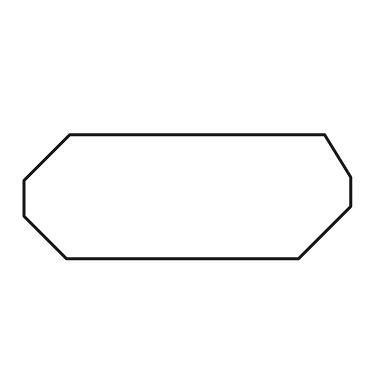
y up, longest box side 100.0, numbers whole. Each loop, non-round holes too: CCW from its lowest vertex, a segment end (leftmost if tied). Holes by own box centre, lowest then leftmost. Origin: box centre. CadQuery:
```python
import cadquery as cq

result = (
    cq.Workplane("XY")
    .moveTo(-37.0, -19.0)
    .lineTo(34.0, -19.0)
    .lineTo(50.0, -3.0)
    .lineTo(50.0, 6.0)
    .lineTo(42.0, 19.0)
    .lineTo(-36.0, 19.0)
    .lineTo(-50.0, 5.0)
    .lineTo(-50.0, -6.0)
    .close()
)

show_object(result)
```